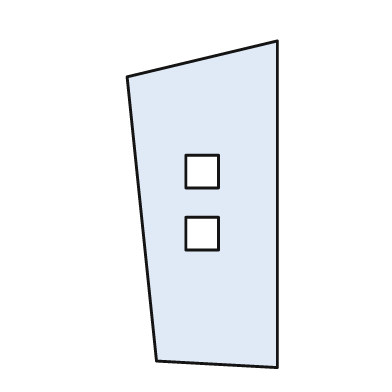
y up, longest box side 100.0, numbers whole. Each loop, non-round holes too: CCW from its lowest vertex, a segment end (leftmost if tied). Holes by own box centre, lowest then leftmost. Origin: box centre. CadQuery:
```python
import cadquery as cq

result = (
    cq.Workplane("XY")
    .moveTo(23.0, -50.0)
    .lineTo(23.0, 50.0)
    .lineTo(-23.0, 39.0)
    .lineTo(-14.0, -48.0)
    .close()
    .moveTo(-5.0, -14.0)
    .lineTo(5.0, -14.0)
    .lineTo(5.0, -4.0)
    .lineTo(-5.0, -4.0)
    .close()
    .moveTo(-5.0, 5.0)
    .lineTo(5.0, 5.0)
    .lineTo(5.0, 15.0)
    .lineTo(-5.0, 15.0)
    .close()
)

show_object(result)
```